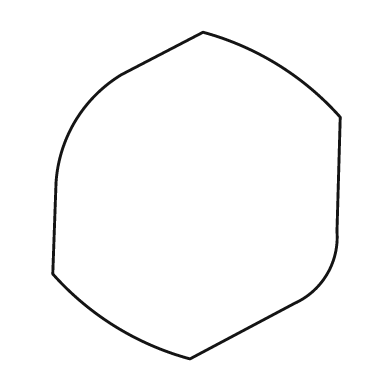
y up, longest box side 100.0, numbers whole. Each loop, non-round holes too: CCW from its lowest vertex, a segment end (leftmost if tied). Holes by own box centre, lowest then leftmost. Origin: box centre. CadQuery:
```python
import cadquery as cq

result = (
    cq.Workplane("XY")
    .moveTo(-2.0, -50.0)
    .lineTo(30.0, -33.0)
    .threePointArc((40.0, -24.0), (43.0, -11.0))
    .lineTo(44.0, 24.0)
    .threePointArc((25.0, 40.0), (2.0, 50.0))
    .lineTo(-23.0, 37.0)
    .threePointArc((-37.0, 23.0), (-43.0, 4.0))
    .lineTo(-44.0, -24.0)
    .threePointArc((-25.0, -40.0), (-2.0, -50.0))
    .close()
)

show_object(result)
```